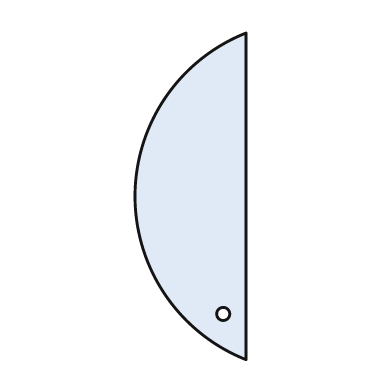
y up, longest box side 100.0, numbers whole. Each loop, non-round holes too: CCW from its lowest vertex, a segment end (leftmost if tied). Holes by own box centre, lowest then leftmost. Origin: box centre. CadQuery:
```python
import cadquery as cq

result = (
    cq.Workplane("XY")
    .moveTo(17.0, -50.0)
    .lineTo(17.0, 50.0)
    .threePointArc((-17.0, 0.0), (17.0, -50.0))
    .close()
    .moveTo(10.0, -36.0)
    .circle(2.0)
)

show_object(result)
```